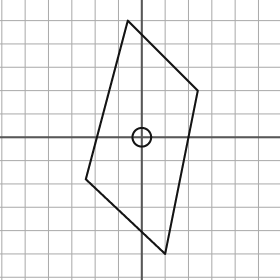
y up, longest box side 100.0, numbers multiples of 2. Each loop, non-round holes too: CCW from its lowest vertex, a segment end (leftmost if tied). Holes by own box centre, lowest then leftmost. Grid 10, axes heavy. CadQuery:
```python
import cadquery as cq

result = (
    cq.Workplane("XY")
    .moveTo(10.0, -50.0)
    .lineTo(24.0, 20.0)
    .lineTo(-6.0, 50.0)
    .lineTo(-24.0, -18.0)
    .close()
    .moveTo(0.0, 0.0)
    .circle(4.0)
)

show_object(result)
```